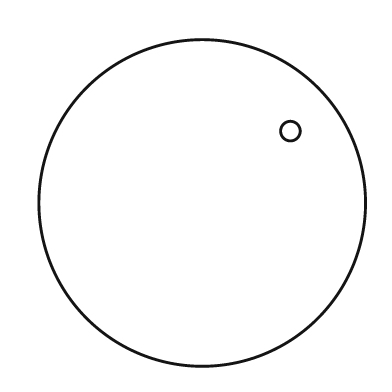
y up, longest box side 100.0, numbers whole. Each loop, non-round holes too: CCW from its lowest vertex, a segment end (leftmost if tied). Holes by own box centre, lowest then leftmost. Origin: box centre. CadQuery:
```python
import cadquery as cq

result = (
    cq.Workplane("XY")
    .moveTo(0.0, 0.0)
    .circle(50.0)
    .moveTo(27.0, 22.0)
    .circle(3.0)
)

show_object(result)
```